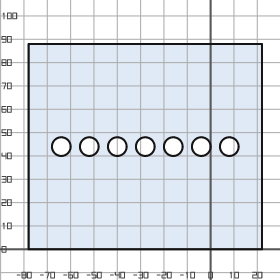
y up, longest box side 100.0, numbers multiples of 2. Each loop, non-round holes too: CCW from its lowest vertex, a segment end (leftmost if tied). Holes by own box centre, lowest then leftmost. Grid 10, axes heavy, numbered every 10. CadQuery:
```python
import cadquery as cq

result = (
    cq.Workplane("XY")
    .moveTo(-78.0, 0.0)
    .lineTo(22.0, 0.0)
    .lineTo(22.0, 88.0)
    .lineTo(-78.0, 88.0)
    .close()
    .moveTo(-64.0, 44.0)
    .circle(4.0)
    .moveTo(-52.0, 44.0)
    .circle(4.0)
    .moveTo(-40.0, 44.0)
    .circle(4.0)
    .moveTo(-28.0, 44.0)
    .circle(4.0)
    .moveTo(-16.0, 44.0)
    .circle(4.0)
    .moveTo(-4.0, 44.0)
    .circle(4.0)
    .moveTo(8.0, 44.0)
    .circle(4.0)
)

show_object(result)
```